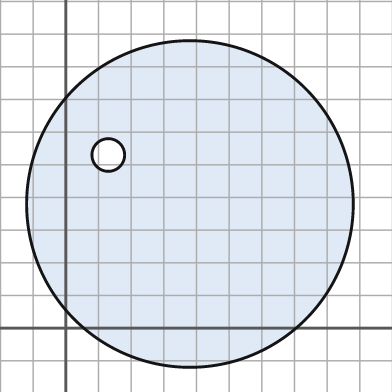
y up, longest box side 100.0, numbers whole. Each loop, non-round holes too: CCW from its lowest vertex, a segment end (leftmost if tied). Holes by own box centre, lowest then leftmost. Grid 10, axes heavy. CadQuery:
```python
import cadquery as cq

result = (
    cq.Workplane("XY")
    .moveTo(38.0, 38.0)
    .circle(50.0)
    .moveTo(13.0, 53.0)
    .circle(5.0)
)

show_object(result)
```